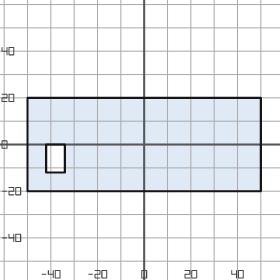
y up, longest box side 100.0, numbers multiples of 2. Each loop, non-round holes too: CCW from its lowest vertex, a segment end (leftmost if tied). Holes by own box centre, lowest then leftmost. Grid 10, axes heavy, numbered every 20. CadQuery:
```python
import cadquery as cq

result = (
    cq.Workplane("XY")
    .moveTo(-50.0, -20.0)
    .lineTo(50.0, -20.0)
    .lineTo(50.0, 20.0)
    .lineTo(-50.0, 20.0)
    .close()
    .moveTo(-42.0, -12.0)
    .lineTo(-34.0, -12.0)
    .lineTo(-34.0, 0.0)
    .lineTo(-42.0, 0.0)
    .close()
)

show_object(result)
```